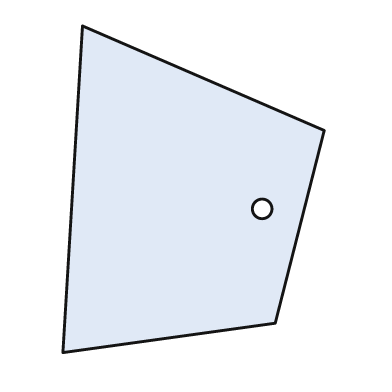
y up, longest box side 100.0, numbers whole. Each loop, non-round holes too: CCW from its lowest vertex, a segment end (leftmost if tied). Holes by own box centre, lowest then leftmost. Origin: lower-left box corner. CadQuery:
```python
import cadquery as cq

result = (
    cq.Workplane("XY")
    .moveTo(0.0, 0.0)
    .lineTo(65.0, 9.0)
    .lineTo(80.0, 68.0)
    .lineTo(6.0, 100.0)
    .close()
    .moveTo(61.0, 44.0)
    .circle(3.0)
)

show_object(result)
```